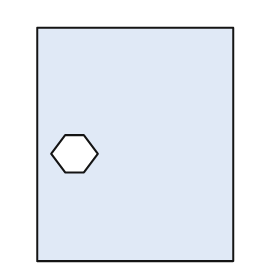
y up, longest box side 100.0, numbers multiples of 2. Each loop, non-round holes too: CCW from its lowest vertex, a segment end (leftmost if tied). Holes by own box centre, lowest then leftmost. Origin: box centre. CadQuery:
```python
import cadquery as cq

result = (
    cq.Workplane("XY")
    .moveTo(-42.0, -50.0)
    .lineTo(42.0, -50.0)
    .lineTo(42.0, 50.0)
    .lineTo(-42.0, 50.0)
    .close()
    .moveTo(-30.0, -12.0)
    .lineTo(-22.0, -12.0)
    .lineTo(-16.0, -4.0)
    .lineTo(-22.0, 4.0)
    .lineTo(-30.0, 4.0)
    .lineTo(-36.0, -4.0)
    .close()
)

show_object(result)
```